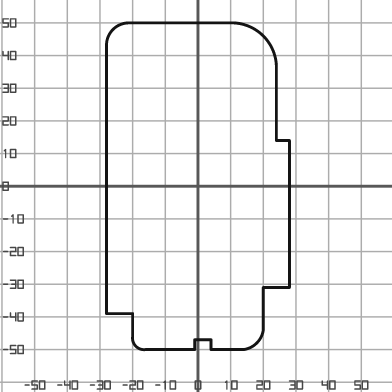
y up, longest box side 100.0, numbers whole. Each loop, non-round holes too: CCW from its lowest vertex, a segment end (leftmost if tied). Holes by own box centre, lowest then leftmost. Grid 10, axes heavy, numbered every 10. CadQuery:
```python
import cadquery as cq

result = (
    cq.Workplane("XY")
    .moveTo(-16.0, -50.0)
    .lineTo(-1.0, -50.0)
    .lineTo(-1.0, -47.0)
    .lineTo(4.0, -47.0)
    .lineTo(4.0, -50.0)
    .lineTo(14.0, -50.0)
    .threePointArc((18.0, -48.0), (20.0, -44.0))
    .lineTo(20.0, -31.0)
    .lineTo(28.0, -31.0)
    .lineTo(28.0, 14.0)
    .lineTo(24.0, 14.0)
    .lineTo(24.0, 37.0)
    .threePointArc((20.0, 46.0), (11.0, 50.0))
    .lineTo(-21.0, 50.0)
    .threePointArc((-26.0, 48.0), (-28.0, 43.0))
    .lineTo(-28.0, -39.0)
    .lineTo(-20.0, -39.0)
    .lineTo(-20.0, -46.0)
    .threePointArc((-19.0, -49.0), (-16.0, -50.0))
    .close()
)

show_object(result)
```